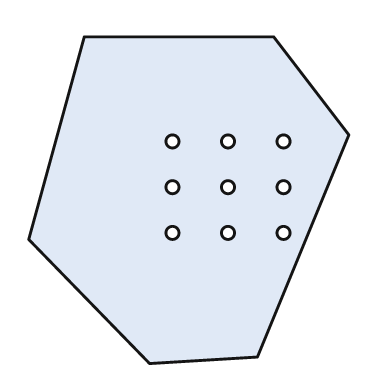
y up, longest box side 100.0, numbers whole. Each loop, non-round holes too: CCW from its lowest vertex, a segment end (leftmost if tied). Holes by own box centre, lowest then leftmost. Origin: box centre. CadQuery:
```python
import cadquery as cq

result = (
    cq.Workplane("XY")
    .moveTo(-12.0, -50.0)
    .lineTo(21.0, -48.0)
    .lineTo(49.0, 20.0)
    .lineTo(26.0, 50.0)
    .lineTo(-32.0, 50.0)
    .lineTo(-49.0, -12.0)
    .close()
    .moveTo(-5.0, -10.0)
    .circle(2.0)
    .moveTo(12.0, -10.0)
    .circle(2.0)
    .moveTo(29.0, -10.0)
    .circle(2.0)
    .moveTo(-5.0, 4.0)
    .circle(2.0)
    .moveTo(12.0, 4.0)
    .circle(2.0)
    .moveTo(29.0, 4.0)
    .circle(2.0)
    .moveTo(-5.0, 18.0)
    .circle(2.0)
    .moveTo(12.0, 18.0)
    .circle(2.0)
    .moveTo(29.0, 18.0)
    .circle(2.0)
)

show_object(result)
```